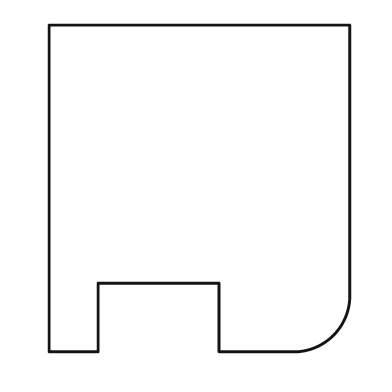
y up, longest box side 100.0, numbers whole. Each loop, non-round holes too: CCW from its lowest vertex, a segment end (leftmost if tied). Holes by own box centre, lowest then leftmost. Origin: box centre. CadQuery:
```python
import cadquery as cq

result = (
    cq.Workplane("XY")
    .moveTo(-46.0, -50.0)
    .lineTo(-31.0, -50.0)
    .lineTo(-31.0, -29.0)
    .lineTo(6.0, -29.0)
    .lineTo(6.0, -50.0)
    .lineTo(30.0, -50.0)
    .threePointArc((41.0, -45.0), (46.0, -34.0))
    .lineTo(46.0, 50.0)
    .lineTo(-46.0, 50.0)
    .close()
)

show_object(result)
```